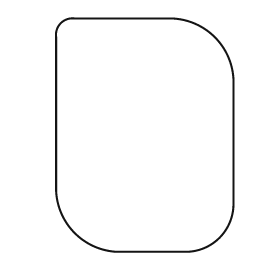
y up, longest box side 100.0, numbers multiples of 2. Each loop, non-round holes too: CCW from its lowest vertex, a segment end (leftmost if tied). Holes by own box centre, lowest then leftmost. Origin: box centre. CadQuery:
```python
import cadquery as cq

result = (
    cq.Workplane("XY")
    .moveTo(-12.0, -50.0)
    .lineTo(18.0, -50.0)
    .threePointArc((32.0, -44.0), (38.0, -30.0))
    .lineTo(38.0, 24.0)
    .threePointArc((30.0, 42.0), (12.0, 50.0))
    .lineTo(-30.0, 50.0)
    .threePointArc((-36.0, 48.0), (-38.0, 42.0))
    .lineTo(-38.0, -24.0)
    .threePointArc((-30.0, -42.0), (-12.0, -50.0))
    .close()
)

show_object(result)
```